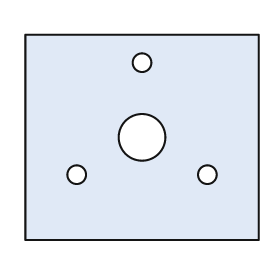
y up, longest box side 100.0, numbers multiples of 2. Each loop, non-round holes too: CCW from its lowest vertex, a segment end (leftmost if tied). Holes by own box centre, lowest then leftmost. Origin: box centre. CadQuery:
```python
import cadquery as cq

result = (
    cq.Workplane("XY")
    .moveTo(-50.0, -44.0)
    .lineTo(50.0, -44.0)
    .lineTo(50.0, 44.0)
    .lineTo(-50.0, 44.0)
    .close()
    .moveTo(-28.0, -16.0)
    .circle(4.0)
    .moveTo(28.0, -16.0)
    .circle(4.0)
    .moveTo(0.0, 0.0)
    .circle(10.0)
    .moveTo(0.0, 32.0)
    .circle(4.0)
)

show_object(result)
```